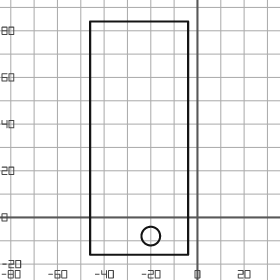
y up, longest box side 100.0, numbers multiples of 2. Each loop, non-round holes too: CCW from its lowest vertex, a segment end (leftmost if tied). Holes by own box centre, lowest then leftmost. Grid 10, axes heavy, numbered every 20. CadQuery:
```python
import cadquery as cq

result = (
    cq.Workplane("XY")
    .moveTo(-46.0, -16.0)
    .lineTo(-4.0, -16.0)
    .lineTo(-4.0, 84.0)
    .lineTo(-46.0, 84.0)
    .close()
    .moveTo(-20.0, -8.0)
    .circle(4.0)
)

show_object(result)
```